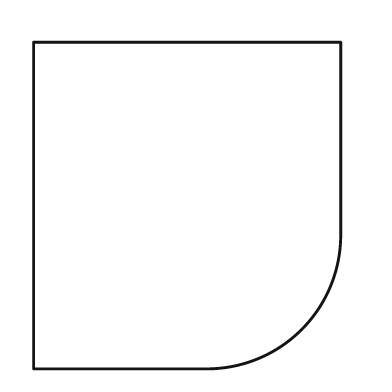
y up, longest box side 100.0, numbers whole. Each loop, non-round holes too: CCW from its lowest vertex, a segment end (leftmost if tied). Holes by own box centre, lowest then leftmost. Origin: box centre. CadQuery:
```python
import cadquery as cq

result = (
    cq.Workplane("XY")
    .moveTo(-47.0, -50.0)
    .lineTo(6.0, -50.0)
    .threePointArc((35.0, -38.0), (47.0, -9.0))
    .lineTo(47.0, 50.0)
    .lineTo(-47.0, 50.0)
    .close()
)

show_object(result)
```